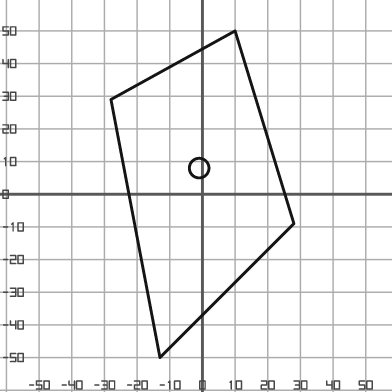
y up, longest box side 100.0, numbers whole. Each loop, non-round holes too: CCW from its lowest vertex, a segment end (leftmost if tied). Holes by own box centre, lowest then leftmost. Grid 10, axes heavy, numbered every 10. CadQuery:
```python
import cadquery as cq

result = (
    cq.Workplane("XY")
    .moveTo(-13.0, -50.0)
    .lineTo(28.0, -9.0)
    .lineTo(10.0, 50.0)
    .lineTo(-28.0, 29.0)
    .close()
    .moveTo(-1.0, 8.0)
    .circle(3.0)
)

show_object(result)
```